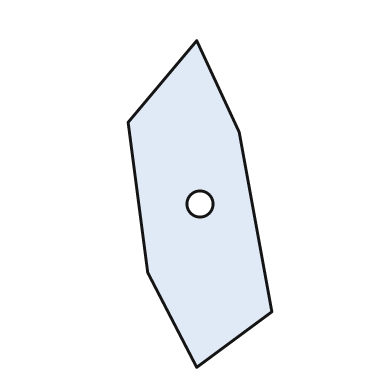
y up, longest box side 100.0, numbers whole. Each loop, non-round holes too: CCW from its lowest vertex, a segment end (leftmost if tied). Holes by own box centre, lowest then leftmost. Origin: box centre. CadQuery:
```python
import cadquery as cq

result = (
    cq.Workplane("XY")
    .moveTo(-1.0, -50.0)
    .lineTo(22.0, -33.0)
    .lineTo(12.0, 22.0)
    .lineTo(-1.0, 50.0)
    .lineTo(-22.0, 25.0)
    .lineTo(-16.0, -21.0)
    .close()
    .moveTo(0.0, 0.0)
    .circle(4.0)
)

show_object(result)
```